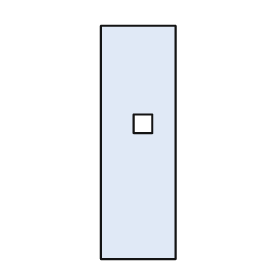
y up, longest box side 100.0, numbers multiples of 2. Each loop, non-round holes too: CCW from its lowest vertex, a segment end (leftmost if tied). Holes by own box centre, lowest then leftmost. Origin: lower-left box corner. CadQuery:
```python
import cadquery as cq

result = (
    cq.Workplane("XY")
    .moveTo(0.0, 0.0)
    .lineTo(32.0, 0.0)
    .lineTo(32.0, 100.0)
    .lineTo(0.0, 100.0)
    .close()
    .moveTo(14.0, 54.0)
    .lineTo(22.0, 54.0)
    .lineTo(22.0, 62.0)
    .lineTo(14.0, 62.0)
    .close()
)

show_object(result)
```